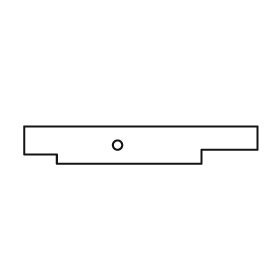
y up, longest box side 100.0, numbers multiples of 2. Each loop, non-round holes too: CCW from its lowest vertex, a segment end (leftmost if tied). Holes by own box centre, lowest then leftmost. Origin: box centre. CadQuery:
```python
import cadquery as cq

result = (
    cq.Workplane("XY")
    .moveTo(-36.0, -8.0)
    .lineTo(26.0, -8.0)
    .lineTo(26.0, -2.0)
    .lineTo(50.0, -2.0)
    .lineTo(50.0, 8.0)
    .lineTo(-50.0, 8.0)
    .lineTo(-50.0, -4.0)
    .lineTo(-36.0, -4.0)
    .close()
    .moveTo(-10.0, 0.0)
    .circle(2.0)
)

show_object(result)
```